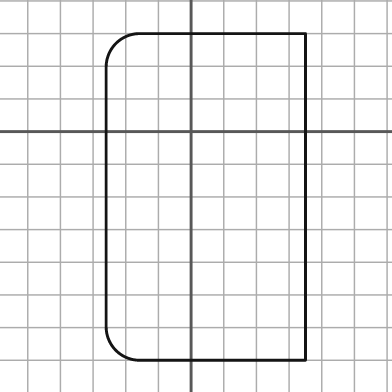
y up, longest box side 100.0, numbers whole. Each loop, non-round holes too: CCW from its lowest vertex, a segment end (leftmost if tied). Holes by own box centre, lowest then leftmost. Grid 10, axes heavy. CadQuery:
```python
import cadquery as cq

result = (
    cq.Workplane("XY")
    .moveTo(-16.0, -70.0)
    .lineTo(35.0, -70.0)
    .lineTo(35.0, 30.0)
    .lineTo(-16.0, 30.0)
    .threePointArc((-23.0, 27.0), (-26.0, 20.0))
    .lineTo(-26.0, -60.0)
    .threePointArc((-23.0, -67.0), (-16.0, -70.0))
    .close()
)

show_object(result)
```